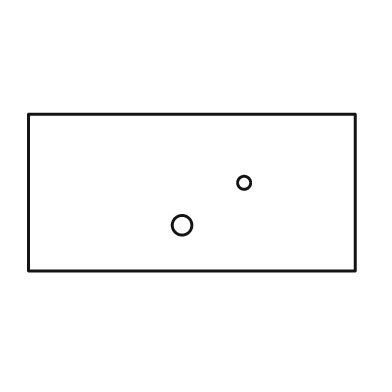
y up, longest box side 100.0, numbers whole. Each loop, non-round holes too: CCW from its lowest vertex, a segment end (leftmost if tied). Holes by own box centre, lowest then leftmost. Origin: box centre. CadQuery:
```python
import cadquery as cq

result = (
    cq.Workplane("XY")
    .moveTo(-50.0, -24.0)
    .lineTo(50.0, -24.0)
    .lineTo(50.0, 24.0)
    .lineTo(-50.0, 24.0)
    .close()
    .moveTo(-3.0, -10.0)
    .circle(3.0)
    .moveTo(16.0, 3.0)
    .circle(2.0)
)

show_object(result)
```